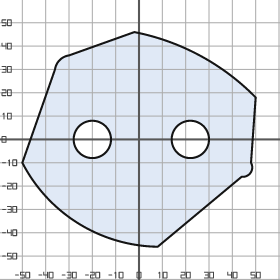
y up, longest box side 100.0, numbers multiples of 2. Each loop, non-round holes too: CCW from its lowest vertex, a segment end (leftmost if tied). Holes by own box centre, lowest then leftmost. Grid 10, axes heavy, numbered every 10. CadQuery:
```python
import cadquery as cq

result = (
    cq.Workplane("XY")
    .moveTo(8.0, -46.0)
    .lineTo(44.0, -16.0)
    .threePointArc((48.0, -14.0), (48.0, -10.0))
    .lineTo(50.0, 18.0)
    .threePointArc((26.0, 36.0), (-2.0, 46.0))
    .lineTo(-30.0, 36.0)
    .threePointArc((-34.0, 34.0), (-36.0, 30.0))
    .lineTo(-50.0, -10.0)
    .threePointArc((-26.0, -36.0), (8.0, -46.0))
    .close()
    .moveTo(-20.0, 0.0)
    .circle(8.0)
    .moveTo(22.0, 0.0)
    .circle(8.0)
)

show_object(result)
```